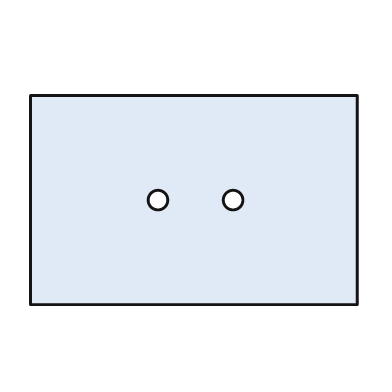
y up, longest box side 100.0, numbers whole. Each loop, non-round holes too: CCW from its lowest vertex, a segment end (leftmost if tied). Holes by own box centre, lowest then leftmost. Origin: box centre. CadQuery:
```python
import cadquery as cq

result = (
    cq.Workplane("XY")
    .moveTo(-50.0, -32.0)
    .lineTo(50.0, -32.0)
    .lineTo(50.0, 32.0)
    .lineTo(-50.0, 32.0)
    .close()
    .moveTo(-11.0, 0.0)
    .circle(3.0)
    .moveTo(12.0, 0.0)
    .circle(3.0)
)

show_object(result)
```